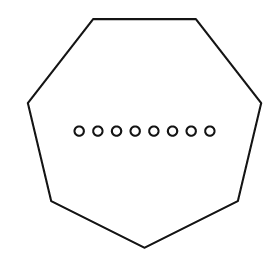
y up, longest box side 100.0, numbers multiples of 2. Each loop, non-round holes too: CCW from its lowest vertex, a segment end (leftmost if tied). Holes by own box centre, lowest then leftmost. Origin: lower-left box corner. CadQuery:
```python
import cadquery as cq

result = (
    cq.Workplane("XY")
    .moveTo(50.0, 0.0)
    .lineTo(90.0, 20.0)
    .lineTo(100.0, 62.0)
    .lineTo(72.0, 98.0)
    .lineTo(28.0, 98.0)
    .lineTo(0.0, 62.0)
    .lineTo(10.0, 20.0)
    .close()
    .moveTo(22.0, 50.0)
    .circle(2.0)
    .moveTo(30.0, 50.0)
    .circle(2.0)
    .moveTo(38.0, 50.0)
    .circle(2.0)
    .moveTo(46.0, 50.0)
    .circle(2.0)
    .moveTo(54.0, 50.0)
    .circle(2.0)
    .moveTo(62.0, 50.0)
    .circle(2.0)
    .moveTo(70.0, 50.0)
    .circle(2.0)
    .moveTo(78.0, 50.0)
    .circle(2.0)
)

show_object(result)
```